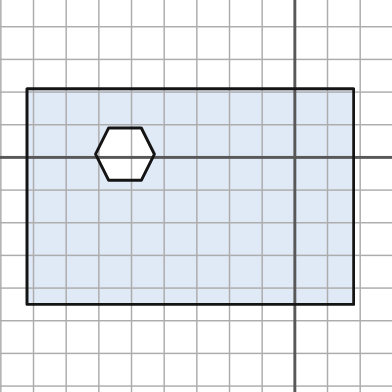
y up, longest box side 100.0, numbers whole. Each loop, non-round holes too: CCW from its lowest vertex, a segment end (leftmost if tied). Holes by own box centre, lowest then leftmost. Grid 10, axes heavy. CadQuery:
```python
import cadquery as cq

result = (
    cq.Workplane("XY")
    .moveTo(-82.0, -45.0)
    .lineTo(18.0, -45.0)
    .lineTo(18.0, 21.0)
    .lineTo(-82.0, 21.0)
    .close()
    .moveTo(-57.0, -7.0)
    .lineTo(-47.0, -7.0)
    .lineTo(-43.0, 1.0)
    .lineTo(-47.0, 9.0)
    .lineTo(-57.0, 9.0)
    .lineTo(-61.0, 1.0)
    .close()
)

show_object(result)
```